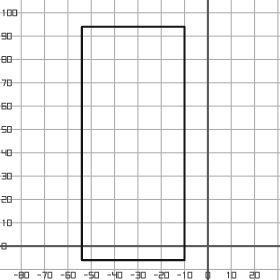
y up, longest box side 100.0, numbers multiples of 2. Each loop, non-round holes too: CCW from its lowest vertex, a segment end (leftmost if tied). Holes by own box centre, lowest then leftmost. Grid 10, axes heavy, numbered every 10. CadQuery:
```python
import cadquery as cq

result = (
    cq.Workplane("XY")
    .moveTo(-54.0, -6.0)
    .lineTo(-10.0, -6.0)
    .lineTo(-10.0, 94.0)
    .lineTo(-54.0, 94.0)
    .close()
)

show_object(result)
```